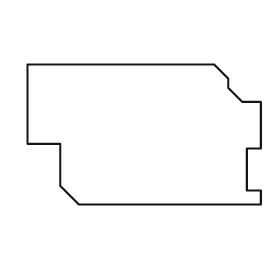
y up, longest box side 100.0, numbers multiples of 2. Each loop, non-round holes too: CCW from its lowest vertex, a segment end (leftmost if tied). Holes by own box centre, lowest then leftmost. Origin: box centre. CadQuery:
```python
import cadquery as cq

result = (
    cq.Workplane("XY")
    .moveTo(-28.0, -30.0)
    .lineTo(50.0, -30.0)
    .lineTo(50.0, -24.0)
    .lineTo(44.0, -24.0)
    .lineTo(44.0, -6.0)
    .lineTo(50.0, -6.0)
    .lineTo(50.0, 14.0)
    .lineTo(42.0, 14.0)
    .lineTo(36.0, 20.0)
    .lineTo(36.0, 24.0)
    .lineTo(30.0, 30.0)
    .lineTo(-50.0, 30.0)
    .lineTo(-50.0, -4.0)
    .lineTo(-36.0, -4.0)
    .lineTo(-36.0, -22.0)
    .close()
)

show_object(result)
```